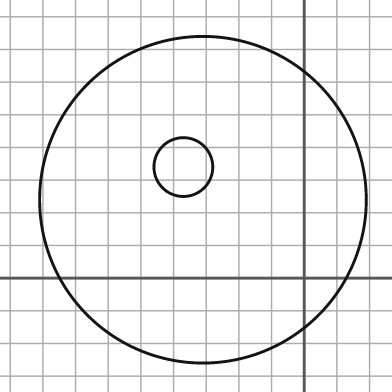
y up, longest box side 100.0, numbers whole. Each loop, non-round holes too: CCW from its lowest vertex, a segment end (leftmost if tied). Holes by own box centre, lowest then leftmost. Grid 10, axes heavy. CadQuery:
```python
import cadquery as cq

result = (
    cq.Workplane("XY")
    .moveTo(-31.0, 24.0)
    .circle(50.0)
    .moveTo(-37.0, 34.0)
    .circle(9.0)
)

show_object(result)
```